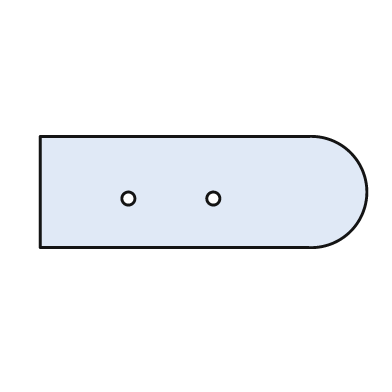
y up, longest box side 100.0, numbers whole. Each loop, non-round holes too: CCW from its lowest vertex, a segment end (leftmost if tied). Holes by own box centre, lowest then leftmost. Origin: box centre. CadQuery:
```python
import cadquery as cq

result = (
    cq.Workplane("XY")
    .moveTo(-50.0, -17.0)
    .lineTo(32.0, -17.0)
    .threePointArc((50.0, 0.0), (32.0, 17.0))
    .lineTo(-50.0, 17.0)
    .close()
    .moveTo(-23.0, -2.0)
    .circle(2.0)
    .moveTo(3.0, -2.0)
    .circle(2.0)
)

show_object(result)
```